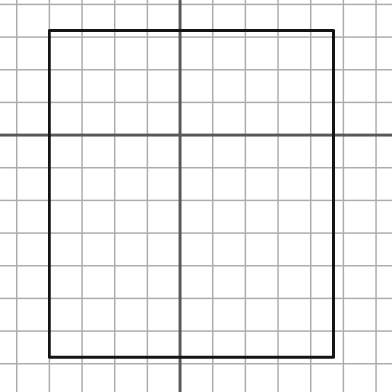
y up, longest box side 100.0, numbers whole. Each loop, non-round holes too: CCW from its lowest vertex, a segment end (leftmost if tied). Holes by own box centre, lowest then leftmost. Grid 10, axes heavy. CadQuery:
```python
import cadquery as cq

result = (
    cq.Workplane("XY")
    .moveTo(-40.0, -68.0)
    .lineTo(47.0, -68.0)
    .lineTo(47.0, 32.0)
    .lineTo(-40.0, 32.0)
    .close()
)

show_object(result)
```